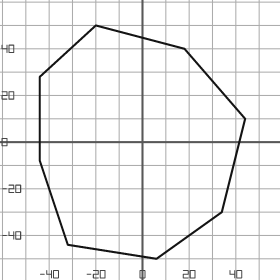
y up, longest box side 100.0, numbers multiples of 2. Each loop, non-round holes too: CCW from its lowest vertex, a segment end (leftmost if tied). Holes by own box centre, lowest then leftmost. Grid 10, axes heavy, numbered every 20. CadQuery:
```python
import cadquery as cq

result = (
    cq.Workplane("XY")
    .moveTo(6.0, -50.0)
    .lineTo(34.0, -30.0)
    .lineTo(44.0, 10.0)
    .lineTo(18.0, 40.0)
    .lineTo(-20.0, 50.0)
    .lineTo(-44.0, 28.0)
    .lineTo(-44.0, -8.0)
    .lineTo(-32.0, -44.0)
    .close()
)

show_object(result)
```